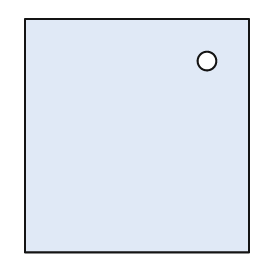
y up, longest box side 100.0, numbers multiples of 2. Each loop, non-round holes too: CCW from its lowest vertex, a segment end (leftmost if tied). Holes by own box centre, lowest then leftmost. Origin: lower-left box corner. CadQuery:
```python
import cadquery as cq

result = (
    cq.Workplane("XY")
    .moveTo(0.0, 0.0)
    .lineTo(96.0, 0.0)
    .lineTo(96.0, 100.0)
    .lineTo(0.0, 100.0)
    .close()
    .moveTo(78.0, 82.0)
    .circle(4.0)
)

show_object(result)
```